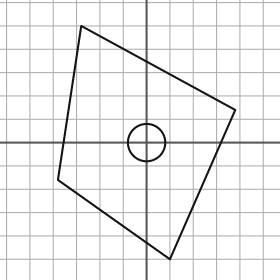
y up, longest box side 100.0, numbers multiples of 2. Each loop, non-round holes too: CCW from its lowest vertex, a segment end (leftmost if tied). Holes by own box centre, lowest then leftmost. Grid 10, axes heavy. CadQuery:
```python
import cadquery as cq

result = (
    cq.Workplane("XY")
    .moveTo(10.0, -50.0)
    .lineTo(38.0, 14.0)
    .lineTo(-28.0, 50.0)
    .lineTo(-38.0, -16.0)
    .close()
    .moveTo(0.0, 0.0)
    .circle(8.0)
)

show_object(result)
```